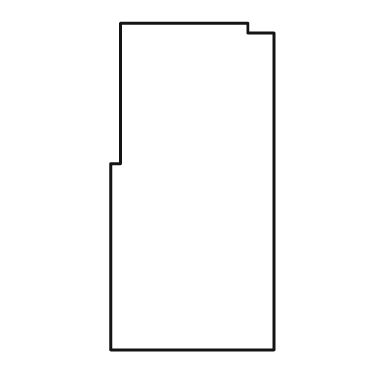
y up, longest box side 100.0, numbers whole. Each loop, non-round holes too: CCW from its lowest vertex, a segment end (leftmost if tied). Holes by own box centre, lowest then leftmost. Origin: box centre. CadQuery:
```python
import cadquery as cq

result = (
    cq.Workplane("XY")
    .moveTo(-25.0, -50.0)
    .lineTo(25.0, -50.0)
    .lineTo(25.0, 47.0)
    .lineTo(17.0, 47.0)
    .lineTo(17.0, 50.0)
    .lineTo(-22.0, 50.0)
    .lineTo(-22.0, 7.0)
    .lineTo(-25.0, 7.0)
    .close()
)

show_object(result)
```